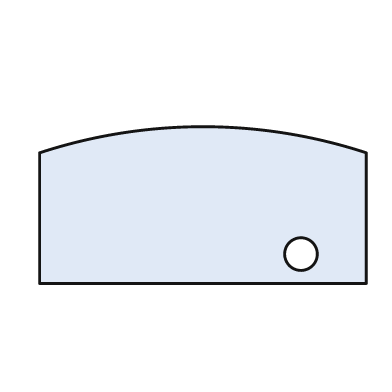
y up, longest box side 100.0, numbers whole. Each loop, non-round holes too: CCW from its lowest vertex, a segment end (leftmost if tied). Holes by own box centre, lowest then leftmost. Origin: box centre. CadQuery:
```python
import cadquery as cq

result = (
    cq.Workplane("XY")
    .moveTo(-50.0, -24.0)
    .lineTo(50.0, -24.0)
    .lineTo(50.0, 16.0)
    .threePointArc((0.0, 24.0), (-50.0, 16.0))
    .close()
    .moveTo(30.0, -15.0)
    .circle(5.0)
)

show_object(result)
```